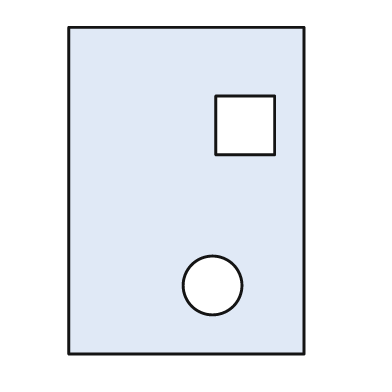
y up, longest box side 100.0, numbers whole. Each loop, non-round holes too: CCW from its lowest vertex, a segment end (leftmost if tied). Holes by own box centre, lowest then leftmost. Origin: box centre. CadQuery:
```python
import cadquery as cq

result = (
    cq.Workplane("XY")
    .moveTo(-36.0, -50.0)
    .lineTo(36.0, -50.0)
    .lineTo(36.0, 50.0)
    .lineTo(-36.0, 50.0)
    .close()
    .moveTo(8.0, -29.0)
    .circle(9.0)
    .moveTo(9.0, 11.0)
    .lineTo(27.0, 11.0)
    .lineTo(27.0, 29.0)
    .lineTo(9.0, 29.0)
    .close()
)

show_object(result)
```